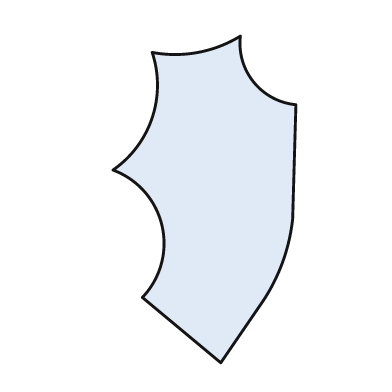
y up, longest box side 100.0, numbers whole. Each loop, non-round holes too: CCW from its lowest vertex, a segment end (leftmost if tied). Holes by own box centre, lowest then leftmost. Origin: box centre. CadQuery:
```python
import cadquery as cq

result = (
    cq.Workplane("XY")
    .moveTo(5.0, -50.0)
    .lineTo(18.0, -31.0)
    .threePointArc((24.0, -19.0), (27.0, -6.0))
    .lineTo(28.0, 29.0)
    .threePointArc((15.0, 36.0), (11.0, 50.0))
    .threePointArc((-2.0, 45.0), (-16.0, 45.0))
    .threePointArc((-16.0, 25.0), (-28.0, 9.0))
    .threePointArc((-13.0, -8.0), (-19.0, -30.0))
    .close()
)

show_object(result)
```